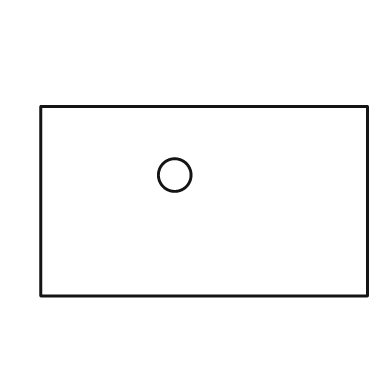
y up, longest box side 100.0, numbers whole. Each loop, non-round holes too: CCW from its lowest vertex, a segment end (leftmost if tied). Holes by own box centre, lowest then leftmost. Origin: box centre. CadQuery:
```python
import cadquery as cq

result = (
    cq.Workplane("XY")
    .moveTo(-50.0, -29.0)
    .lineTo(50.0, -29.0)
    .lineTo(50.0, 29.0)
    .lineTo(-50.0, 29.0)
    .close()
    .moveTo(-9.0, 8.0)
    .circle(5.0)
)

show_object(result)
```